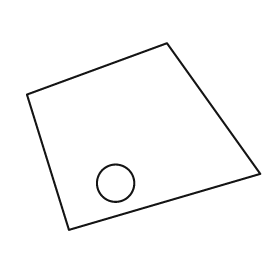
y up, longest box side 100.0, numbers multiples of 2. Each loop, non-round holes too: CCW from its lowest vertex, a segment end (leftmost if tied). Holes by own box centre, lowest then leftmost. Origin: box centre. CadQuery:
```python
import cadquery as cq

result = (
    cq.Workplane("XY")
    .moveTo(-32.0, -40.0)
    .lineTo(50.0, -16.0)
    .lineTo(10.0, 40.0)
    .lineTo(-50.0, 18.0)
    .close()
    .moveTo(-12.0, -20.0)
    .circle(8.0)
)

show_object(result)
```